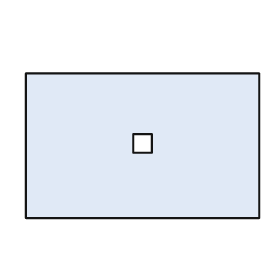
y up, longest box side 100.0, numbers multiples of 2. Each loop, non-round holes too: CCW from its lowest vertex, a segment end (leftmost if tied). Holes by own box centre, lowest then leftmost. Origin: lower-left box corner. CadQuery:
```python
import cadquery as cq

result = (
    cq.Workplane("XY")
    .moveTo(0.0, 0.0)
    .lineTo(100.0, 0.0)
    .lineTo(100.0, 62.0)
    .lineTo(0.0, 62.0)
    .close()
    .moveTo(46.0, 28.0)
    .lineTo(54.0, 28.0)
    .lineTo(54.0, 36.0)
    .lineTo(46.0, 36.0)
    .close()
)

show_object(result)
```